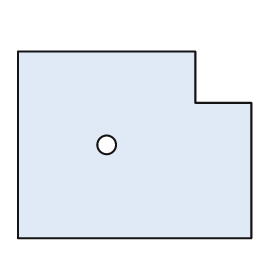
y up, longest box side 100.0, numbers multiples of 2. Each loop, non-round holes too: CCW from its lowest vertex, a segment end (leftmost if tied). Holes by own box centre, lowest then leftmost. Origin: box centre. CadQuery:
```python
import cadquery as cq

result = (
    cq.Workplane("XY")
    .moveTo(-50.0, -40.0)
    .lineTo(50.0, -40.0)
    .lineTo(50.0, 18.0)
    .lineTo(26.0, 18.0)
    .lineTo(26.0, 40.0)
    .lineTo(-50.0, 40.0)
    .close()
    .moveTo(-12.0, 0.0)
    .circle(4.0)
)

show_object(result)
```